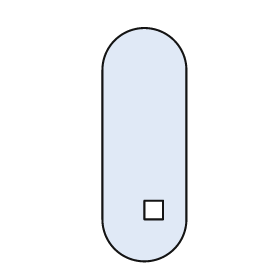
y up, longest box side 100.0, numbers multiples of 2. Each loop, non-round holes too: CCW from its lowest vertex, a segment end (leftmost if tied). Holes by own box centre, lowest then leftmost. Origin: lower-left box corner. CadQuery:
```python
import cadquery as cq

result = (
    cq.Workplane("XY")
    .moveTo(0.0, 18.0)
    .threePointArc((18.0, 0.0), (36.0, 18.0))
    .lineTo(36.0, 82.0)
    .threePointArc((18.0, 100.0), (0.0, 82.0))
    .close()
    .moveTo(18.0, 18.0)
    .lineTo(26.0, 18.0)
    .lineTo(26.0, 26.0)
    .lineTo(18.0, 26.0)
    .close()
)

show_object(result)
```